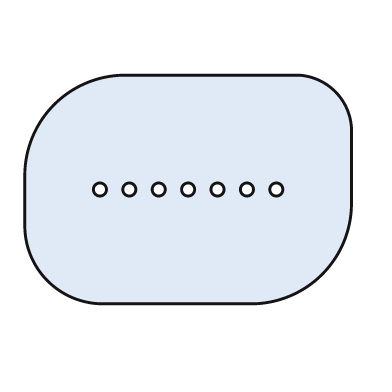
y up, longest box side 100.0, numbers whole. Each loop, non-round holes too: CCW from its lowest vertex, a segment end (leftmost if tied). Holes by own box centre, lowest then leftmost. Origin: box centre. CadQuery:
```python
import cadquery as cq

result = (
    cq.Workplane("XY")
    .moveTo(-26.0, -35.0)
    .lineTo(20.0, -35.0)
    .threePointArc((41.0, -26.0), (50.0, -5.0))
    .lineTo(50.0, 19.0)
    .threePointArc((45.0, 30.0), (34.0, 35.0))
    .lineTo(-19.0, 35.0)
    .threePointArc((-41.0, 26.0), (-50.0, 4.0))
    .lineTo(-50.0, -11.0)
    .threePointArc((-43.0, -28.0), (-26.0, -35.0))
    .close()
    .moveTo(-27.0, 0.0)
    .circle(2.0)
    .moveTo(-18.0, 0.0)
    .circle(2.0)
    .moveTo(-9.0, 0.0)
    .circle(2.0)
    .moveTo(0.0, 0.0)
    .circle(2.0)
    .moveTo(9.0, 0.0)
    .circle(2.0)
    .moveTo(18.0, 0.0)
    .circle(2.0)
    .moveTo(27.0, 0.0)
    .circle(2.0)
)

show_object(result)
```